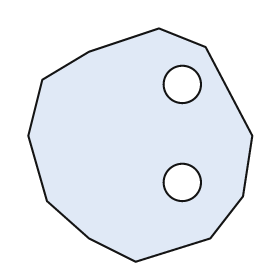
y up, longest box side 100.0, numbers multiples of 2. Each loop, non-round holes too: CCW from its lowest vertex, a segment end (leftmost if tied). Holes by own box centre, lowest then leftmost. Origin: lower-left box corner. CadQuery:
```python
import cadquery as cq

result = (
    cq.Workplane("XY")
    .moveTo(46.0, 0.0)
    .lineTo(78.0, 10.0)
    .lineTo(92.0, 28.0)
    .lineTo(96.0, 54.0)
    .lineTo(76.0, 92.0)
    .lineTo(56.0, 100.0)
    .lineTo(26.0, 90.0)
    .lineTo(6.0, 78.0)
    .lineTo(0.0, 54.0)
    .lineTo(8.0, 26.0)
    .lineTo(26.0, 10.0)
    .close()
    .moveTo(66.0, 34.0)
    .circle(8.0)
    .moveTo(66.0, 76.0)
    .circle(8.0)
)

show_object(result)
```